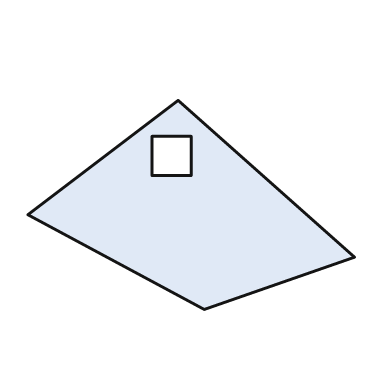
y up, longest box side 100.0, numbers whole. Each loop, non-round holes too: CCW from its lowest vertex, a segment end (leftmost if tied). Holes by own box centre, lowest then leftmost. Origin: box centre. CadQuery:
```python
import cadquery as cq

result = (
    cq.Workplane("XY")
    .moveTo(4.0, -32.0)
    .lineTo(50.0, -16.0)
    .lineTo(-4.0, 32.0)
    .lineTo(-50.0, -3.0)
    .close()
    .moveTo(-12.0, 9.0)
    .lineTo(0.0, 9.0)
    .lineTo(0.0, 21.0)
    .lineTo(-12.0, 21.0)
    .close()
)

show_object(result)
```